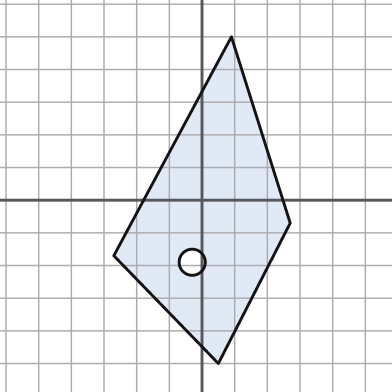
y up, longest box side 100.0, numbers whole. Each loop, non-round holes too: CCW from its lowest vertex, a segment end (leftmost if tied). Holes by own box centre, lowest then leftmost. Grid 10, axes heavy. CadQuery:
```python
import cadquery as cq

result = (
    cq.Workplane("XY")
    .moveTo(5.0, -50.0)
    .lineTo(27.0, -7.0)
    .lineTo(9.0, 50.0)
    .lineTo(-27.0, -17.0)
    .close()
    .moveTo(-3.0, -19.0)
    .circle(4.0)
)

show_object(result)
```